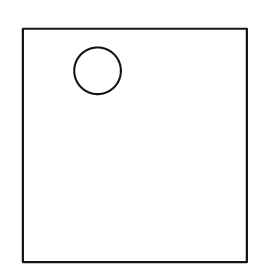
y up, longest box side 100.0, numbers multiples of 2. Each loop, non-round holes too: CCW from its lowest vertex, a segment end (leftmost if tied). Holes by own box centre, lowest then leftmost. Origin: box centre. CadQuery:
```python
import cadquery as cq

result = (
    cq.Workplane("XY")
    .moveTo(-48.0, -50.0)
    .lineTo(48.0, -50.0)
    .lineTo(48.0, 50.0)
    .lineTo(-48.0, 50.0)
    .close()
    .moveTo(-16.0, 32.0)
    .circle(10.0)
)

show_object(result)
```